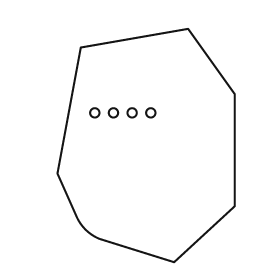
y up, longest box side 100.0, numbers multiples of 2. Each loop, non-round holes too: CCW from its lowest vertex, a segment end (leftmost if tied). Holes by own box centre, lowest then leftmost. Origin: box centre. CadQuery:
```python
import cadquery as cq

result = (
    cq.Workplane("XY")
    .moveTo(12.0, -50.0)
    .lineTo(38.0, -26.0)
    .lineTo(38.0, 22.0)
    .lineTo(18.0, 50.0)
    .lineTo(-28.0, 42.0)
    .lineTo(-38.0, -12.0)
    .lineTo(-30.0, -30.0)
    .threePointArc((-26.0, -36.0), (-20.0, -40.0))
    .close()
    .moveTo(-22.0, 14.0)
    .circle(2.0)
    .moveTo(-14.0, 14.0)
    .circle(2.0)
    .moveTo(-6.0, 14.0)
    .circle(2.0)
    .moveTo(2.0, 14.0)
    .circle(2.0)
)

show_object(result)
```